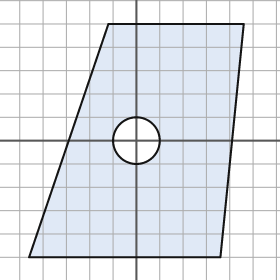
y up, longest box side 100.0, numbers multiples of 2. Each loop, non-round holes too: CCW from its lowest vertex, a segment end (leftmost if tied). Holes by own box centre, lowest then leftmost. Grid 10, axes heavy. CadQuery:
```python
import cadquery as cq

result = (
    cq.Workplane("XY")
    .moveTo(-46.0, -50.0)
    .lineTo(36.0, -50.0)
    .lineTo(46.0, 50.0)
    .lineTo(-12.0, 50.0)
    .close()
    .moveTo(0.0, 0.0)
    .circle(10.0)
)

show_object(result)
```